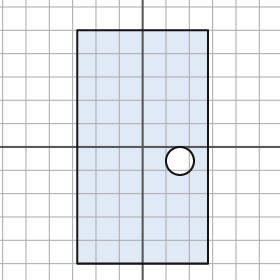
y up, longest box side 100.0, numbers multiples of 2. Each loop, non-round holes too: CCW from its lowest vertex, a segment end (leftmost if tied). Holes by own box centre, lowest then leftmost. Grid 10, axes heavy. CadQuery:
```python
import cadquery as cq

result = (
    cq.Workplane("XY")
    .moveTo(-28.0, -50.0)
    .lineTo(28.0, -50.0)
    .lineTo(28.0, 50.0)
    .lineTo(-28.0, 50.0)
    .close()
    .moveTo(16.0, -6.0)
    .circle(6.0)
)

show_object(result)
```